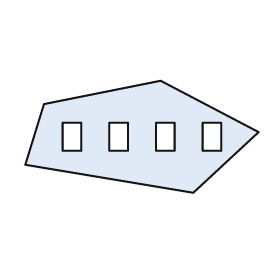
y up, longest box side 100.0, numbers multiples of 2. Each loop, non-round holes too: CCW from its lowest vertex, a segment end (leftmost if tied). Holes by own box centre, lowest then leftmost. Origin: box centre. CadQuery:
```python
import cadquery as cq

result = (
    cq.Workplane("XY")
    .moveTo(22.0, -24.0)
    .lineTo(50.0, 2.0)
    .lineTo(8.0, 24.0)
    .lineTo(-42.0, 14.0)
    .lineTo(-50.0, -12.0)
    .close()
    .moveTo(-34.0, -6.0)
    .lineTo(-26.0, -6.0)
    .lineTo(-26.0, 6.0)
    .lineTo(-34.0, 6.0)
    .close()
    .moveTo(-14.0, -6.0)
    .lineTo(-6.0, -6.0)
    .lineTo(-6.0, 6.0)
    .lineTo(-14.0, 6.0)
    .close()
    .moveTo(6.0, -6.0)
    .lineTo(14.0, -6.0)
    .lineTo(14.0, 6.0)
    .lineTo(6.0, 6.0)
    .close()
    .moveTo(26.0, -6.0)
    .lineTo(34.0, -6.0)
    .lineTo(34.0, 6.0)
    .lineTo(26.0, 6.0)
    .close()
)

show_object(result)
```